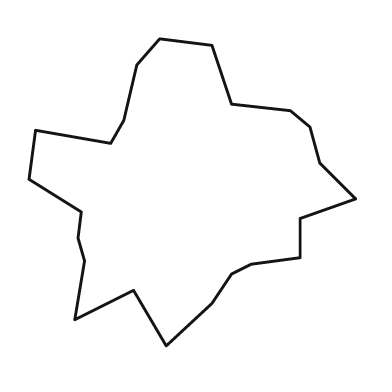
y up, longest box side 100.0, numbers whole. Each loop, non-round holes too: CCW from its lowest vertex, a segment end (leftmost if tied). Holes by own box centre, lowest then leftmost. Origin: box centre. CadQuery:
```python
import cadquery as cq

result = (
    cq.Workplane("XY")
    .moveTo(-8.0, -47.0)
    .lineTo(6.0, -34.0)
    .lineTo(12.0, -25.0)
    .lineTo(18.0, -22.0)
    .lineTo(33.0, -20.0)
    .lineTo(33.0, -8.0)
    .lineTo(50.0, -2.0)
    .lineTo(39.0, 9.0)
    .lineTo(36.0, 20.0)
    .lineTo(30.0, 25.0)
    .lineTo(12.0, 27.0)
    .lineTo(6.0, 45.0)
    .lineTo(-10.0, 47.0)
    .lineTo(-17.0, 39.0)
    .lineTo(-21.0, 22.0)
    .lineTo(-25.0, 15.0)
    .lineTo(-48.0, 19.0)
    .lineTo(-50.0, 4.0)
    .lineTo(-34.0, -6.0)
    .lineTo(-35.0, -14.0)
    .lineTo(-33.0, -21.0)
    .lineTo(-36.0, -39.0)
    .lineTo(-18.0, -30.0)
    .close()
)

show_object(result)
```